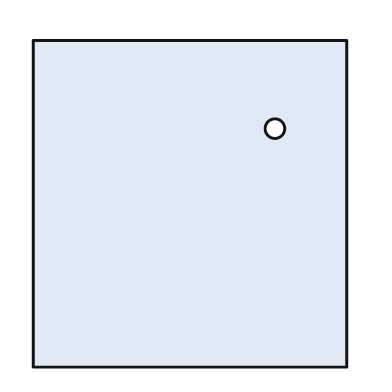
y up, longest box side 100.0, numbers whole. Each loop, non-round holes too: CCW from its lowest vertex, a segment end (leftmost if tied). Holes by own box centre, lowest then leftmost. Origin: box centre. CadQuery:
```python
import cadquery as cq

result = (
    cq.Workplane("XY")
    .moveTo(-48.0, -50.0)
    .lineTo(48.0, -50.0)
    .lineTo(48.0, 50.0)
    .lineTo(-48.0, 50.0)
    .close()
    .moveTo(26.0, 23.0)
    .circle(3.0)
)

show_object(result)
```